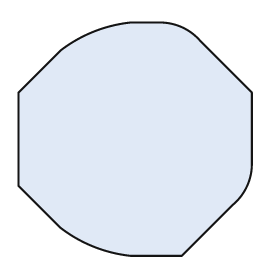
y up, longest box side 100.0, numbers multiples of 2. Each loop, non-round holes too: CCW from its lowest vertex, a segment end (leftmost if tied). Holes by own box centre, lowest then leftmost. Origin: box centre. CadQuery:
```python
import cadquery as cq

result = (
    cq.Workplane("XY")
    .moveTo(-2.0, -50.0)
    .lineTo(20.0, -50.0)
    .lineTo(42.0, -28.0)
    .threePointArc((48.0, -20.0), (50.0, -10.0))
    .lineTo(50.0, 20.0)
    .lineTo(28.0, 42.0)
    .threePointArc((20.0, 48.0), (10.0, 50.0))
    .lineTo(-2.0, 50.0)
    .threePointArc((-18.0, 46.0), (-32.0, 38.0))
    .lineTo(-50.0, 20.0)
    .lineTo(-50.0, -20.0)
    .lineTo(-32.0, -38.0)
    .threePointArc((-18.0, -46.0), (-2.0, -50.0))
    .close()
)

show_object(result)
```